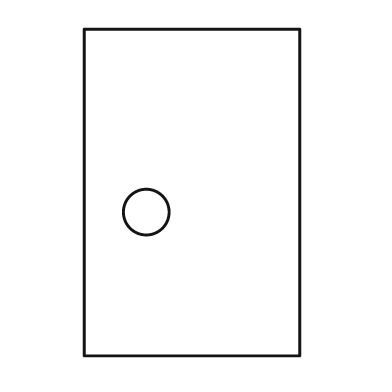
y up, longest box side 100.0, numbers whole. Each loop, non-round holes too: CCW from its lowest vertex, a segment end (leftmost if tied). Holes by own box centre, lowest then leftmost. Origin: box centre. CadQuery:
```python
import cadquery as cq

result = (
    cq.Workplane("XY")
    .moveTo(-33.0, -50.0)
    .lineTo(33.0, -50.0)
    .lineTo(33.0, 50.0)
    .lineTo(-33.0, 50.0)
    .close()
    .moveTo(-14.0, -6.0)
    .circle(7.0)
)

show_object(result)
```